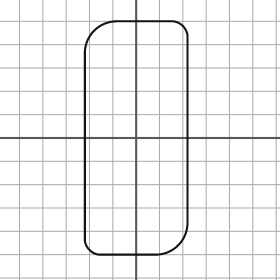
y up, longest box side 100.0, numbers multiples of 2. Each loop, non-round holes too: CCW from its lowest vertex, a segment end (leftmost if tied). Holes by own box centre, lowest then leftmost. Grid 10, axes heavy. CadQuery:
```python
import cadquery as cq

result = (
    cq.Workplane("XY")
    .moveTo(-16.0, -50.0)
    .lineTo(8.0, -50.0)
    .threePointArc((18.0, -46.0), (22.0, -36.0))
    .lineTo(22.0, 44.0)
    .threePointArc((20.0, 48.0), (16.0, 50.0))
    .lineTo(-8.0, 50.0)
    .threePointArc((-18.0, 46.0), (-22.0, 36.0))
    .lineTo(-22.0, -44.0)
    .threePointArc((-20.0, -48.0), (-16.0, -50.0))
    .close()
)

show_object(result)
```